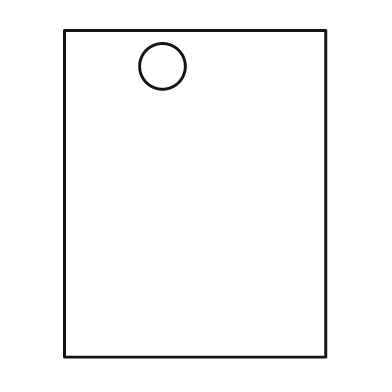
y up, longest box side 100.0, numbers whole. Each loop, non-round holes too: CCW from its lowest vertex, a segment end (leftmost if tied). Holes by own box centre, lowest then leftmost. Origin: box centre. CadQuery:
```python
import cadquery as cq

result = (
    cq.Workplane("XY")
    .moveTo(-40.0, -50.0)
    .lineTo(40.0, -50.0)
    .lineTo(40.0, 50.0)
    .lineTo(-40.0, 50.0)
    .close()
    .moveTo(-10.0, 39.0)
    .circle(7.0)
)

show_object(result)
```